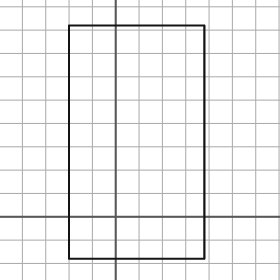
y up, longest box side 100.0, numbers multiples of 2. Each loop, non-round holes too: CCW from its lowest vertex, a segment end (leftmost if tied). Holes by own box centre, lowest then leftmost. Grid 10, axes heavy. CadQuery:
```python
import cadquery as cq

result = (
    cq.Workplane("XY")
    .moveTo(-20.0, -18.0)
    .lineTo(38.0, -18.0)
    .lineTo(38.0, 82.0)
    .lineTo(-20.0, 82.0)
    .close()
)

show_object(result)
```